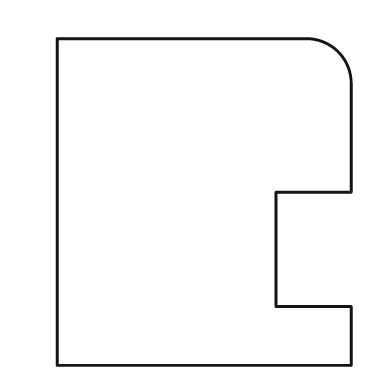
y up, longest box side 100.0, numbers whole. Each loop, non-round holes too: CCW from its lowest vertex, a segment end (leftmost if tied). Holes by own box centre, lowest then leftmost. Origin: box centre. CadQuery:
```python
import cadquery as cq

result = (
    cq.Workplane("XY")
    .moveTo(-45.0, -50.0)
    .lineTo(45.0, -50.0)
    .lineTo(45.0, -32.0)
    .lineTo(22.0, -32.0)
    .lineTo(22.0, 3.0)
    .lineTo(45.0, 3.0)
    .lineTo(45.0, 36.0)
    .threePointArc((41.0, 46.0), (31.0, 50.0))
    .lineTo(-45.0, 50.0)
    .close()
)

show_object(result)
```